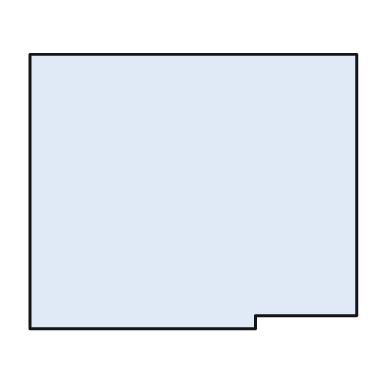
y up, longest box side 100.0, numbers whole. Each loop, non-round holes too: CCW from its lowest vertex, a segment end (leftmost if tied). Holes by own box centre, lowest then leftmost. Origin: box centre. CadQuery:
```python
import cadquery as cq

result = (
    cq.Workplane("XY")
    .moveTo(-50.0, -42.0)
    .lineTo(19.0, -42.0)
    .lineTo(19.0, -38.0)
    .lineTo(50.0, -38.0)
    .lineTo(50.0, 42.0)
    .lineTo(-50.0, 42.0)
    .close()
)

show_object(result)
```